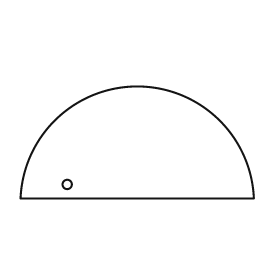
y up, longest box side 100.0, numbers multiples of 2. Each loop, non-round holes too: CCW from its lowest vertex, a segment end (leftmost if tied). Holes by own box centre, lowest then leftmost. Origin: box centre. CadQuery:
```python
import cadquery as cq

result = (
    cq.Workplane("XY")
    .moveTo(-50.0, -24.0)
    .lineTo(50.0, -24.0)
    .threePointArc((0.0, 24.0), (-50.0, -24.0))
    .close()
    .moveTo(-30.0, -18.0)
    .circle(2.0)
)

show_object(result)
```